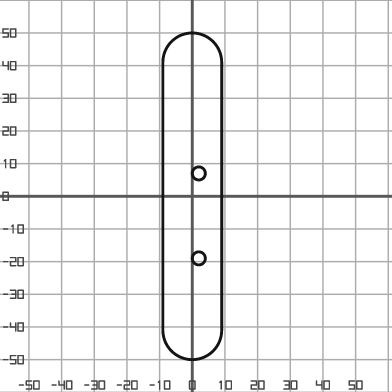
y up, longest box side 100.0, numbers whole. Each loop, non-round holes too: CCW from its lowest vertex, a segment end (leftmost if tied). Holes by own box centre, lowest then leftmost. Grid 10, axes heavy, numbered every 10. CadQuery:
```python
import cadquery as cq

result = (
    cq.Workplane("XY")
    .moveTo(-9.0, -41.0)
    .threePointArc((0.0, -50.0), (9.0, -41.0))
    .lineTo(9.0, 41.0)
    .threePointArc((0.0, 50.0), (-9.0, 41.0))
    .close()
    .moveTo(2.0, -19.0)
    .circle(2.0)
    .moveTo(2.0, 7.0)
    .circle(2.0)
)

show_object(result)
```